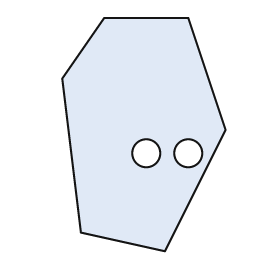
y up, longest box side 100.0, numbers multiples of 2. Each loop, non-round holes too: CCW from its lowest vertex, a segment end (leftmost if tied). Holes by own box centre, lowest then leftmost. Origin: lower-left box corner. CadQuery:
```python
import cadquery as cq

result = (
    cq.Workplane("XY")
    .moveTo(44.0, 0.0)
    .lineTo(70.0, 52.0)
    .lineTo(54.0, 100.0)
    .lineTo(18.0, 100.0)
    .lineTo(0.0, 74.0)
    .lineTo(8.0, 8.0)
    .close()
    .moveTo(36.0, 42.0)
    .circle(6.0)
    .moveTo(54.0, 42.0)
    .circle(6.0)
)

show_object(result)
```